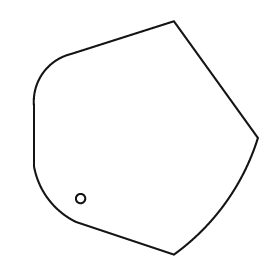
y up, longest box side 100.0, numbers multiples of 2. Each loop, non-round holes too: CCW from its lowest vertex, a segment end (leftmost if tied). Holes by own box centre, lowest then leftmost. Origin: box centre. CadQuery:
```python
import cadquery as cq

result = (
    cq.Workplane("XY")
    .moveTo(12.0, -50.0)
    .threePointArc((34.0, -28.0), (48.0, 0.0))
    .lineTo(12.0, 50.0)
    .lineTo(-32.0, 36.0)
    .threePointArc((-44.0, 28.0), (-48.0, 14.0))
    .lineTo(-48.0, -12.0)
    .threePointArc((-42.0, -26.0), (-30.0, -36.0))
    .close()
    .moveTo(-28.0, -26.0)
    .circle(2.0)
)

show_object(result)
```